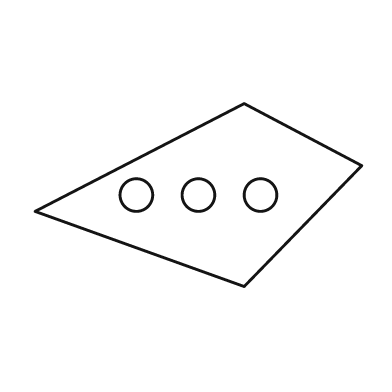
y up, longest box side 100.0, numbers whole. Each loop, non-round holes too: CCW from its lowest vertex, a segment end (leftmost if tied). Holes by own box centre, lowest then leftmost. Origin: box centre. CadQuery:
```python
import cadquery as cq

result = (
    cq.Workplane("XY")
    .moveTo(14.0, -28.0)
    .lineTo(50.0, 9.0)
    .lineTo(14.0, 28.0)
    .lineTo(-50.0, -5.0)
    .close()
    .moveTo(-19.0, 0.0)
    .circle(5.0)
    .moveTo(0.0, 0.0)
    .circle(5.0)
    .moveTo(19.0, 0.0)
    .circle(5.0)
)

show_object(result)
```